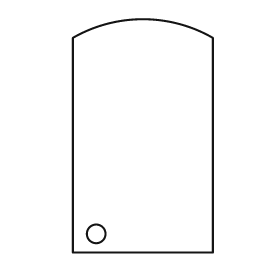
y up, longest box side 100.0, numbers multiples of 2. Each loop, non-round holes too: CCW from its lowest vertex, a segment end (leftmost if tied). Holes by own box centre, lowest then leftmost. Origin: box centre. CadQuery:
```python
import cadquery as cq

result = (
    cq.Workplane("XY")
    .moveTo(-30.0, -50.0)
    .lineTo(30.0, -50.0)
    .lineTo(30.0, 42.0)
    .threePointArc((0.0, 50.0), (-30.0, 42.0))
    .close()
    .moveTo(-20.0, -42.0)
    .circle(4.0)
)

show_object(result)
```